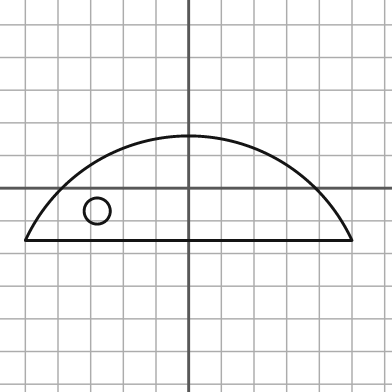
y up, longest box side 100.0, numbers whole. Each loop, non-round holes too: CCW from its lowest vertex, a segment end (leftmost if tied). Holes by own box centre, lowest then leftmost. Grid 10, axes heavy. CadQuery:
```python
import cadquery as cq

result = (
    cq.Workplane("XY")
    .moveTo(-50.0, -16.0)
    .lineTo(50.0, -16.0)
    .threePointArc((0.0, 16.0), (-50.0, -16.0))
    .close()
    .moveTo(-28.0, -7.0)
    .circle(4.0)
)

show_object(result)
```